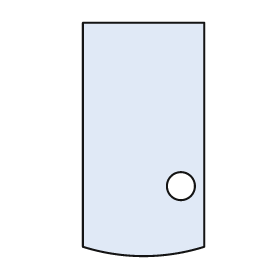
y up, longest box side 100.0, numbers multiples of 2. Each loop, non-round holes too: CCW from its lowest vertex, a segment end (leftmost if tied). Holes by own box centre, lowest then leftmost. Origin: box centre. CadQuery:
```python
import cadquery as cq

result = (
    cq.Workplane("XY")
    .moveTo(-26.0, -46.0)
    .threePointArc((0.0, -50.0), (26.0, -46.0))
    .lineTo(26.0, 50.0)
    .lineTo(-26.0, 50.0)
    .close()
    .moveTo(16.0, -20.0)
    .circle(6.0)
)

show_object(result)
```